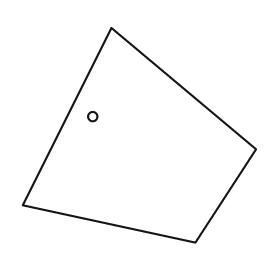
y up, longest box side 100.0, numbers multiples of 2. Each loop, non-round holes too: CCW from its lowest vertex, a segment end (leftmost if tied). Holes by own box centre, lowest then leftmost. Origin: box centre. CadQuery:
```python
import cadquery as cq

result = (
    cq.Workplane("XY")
    .moveTo(24.0, -46.0)
    .lineTo(50.0, -6.0)
    .lineTo(-12.0, 46.0)
    .lineTo(-50.0, -30.0)
    .close()
    .moveTo(-20.0, 8.0)
    .circle(2.0)
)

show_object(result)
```